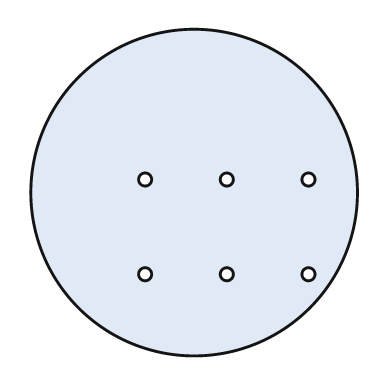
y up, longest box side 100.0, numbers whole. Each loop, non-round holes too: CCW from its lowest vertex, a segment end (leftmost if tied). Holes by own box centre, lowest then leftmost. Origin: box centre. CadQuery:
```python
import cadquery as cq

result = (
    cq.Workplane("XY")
    .moveTo(0.0, 0.0)
    .circle(50.0)
    .moveTo(-15.0, -25.0)
    .circle(2.0)
    .moveTo(10.0, -25.0)
    .circle(2.0)
    .moveTo(35.0, -25.0)
    .circle(2.0)
    .moveTo(-15.0, 4.0)
    .circle(2.0)
    .moveTo(10.0, 4.0)
    .circle(2.0)
    .moveTo(35.0, 4.0)
    .circle(2.0)
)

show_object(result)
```